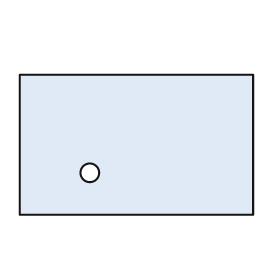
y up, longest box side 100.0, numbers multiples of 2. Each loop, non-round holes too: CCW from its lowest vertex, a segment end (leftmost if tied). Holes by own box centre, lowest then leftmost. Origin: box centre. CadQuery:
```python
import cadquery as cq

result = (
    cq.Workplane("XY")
    .moveTo(-50.0, -30.0)
    .lineTo(50.0, -30.0)
    .lineTo(50.0, 30.0)
    .lineTo(-50.0, 30.0)
    .close()
    .moveTo(-20.0, -12.0)
    .circle(4.0)
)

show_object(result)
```